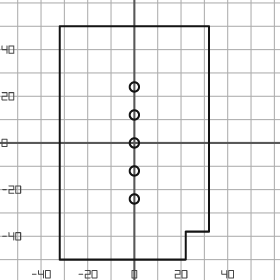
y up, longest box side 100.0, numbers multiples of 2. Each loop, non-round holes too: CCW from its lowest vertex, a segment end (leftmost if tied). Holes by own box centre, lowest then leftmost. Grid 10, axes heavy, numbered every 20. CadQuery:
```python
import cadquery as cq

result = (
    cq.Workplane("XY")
    .moveTo(-32.0, -50.0)
    .lineTo(22.0, -50.0)
    .lineTo(22.0, -38.0)
    .lineTo(32.0, -38.0)
    .lineTo(32.0, 50.0)
    .lineTo(-32.0, 50.0)
    .close()
    .moveTo(0.0, -24.0)
    .circle(2.0)
    .moveTo(0.0, -12.0)
    .circle(2.0)
    .moveTo(0.0, 0.0)
    .circle(2.0)
    .moveTo(0.0, 12.0)
    .circle(2.0)
    .moveTo(0.0, 24.0)
    .circle(2.0)
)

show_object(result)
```